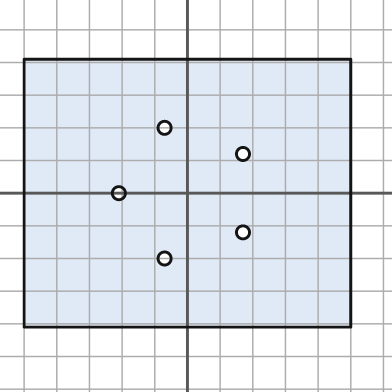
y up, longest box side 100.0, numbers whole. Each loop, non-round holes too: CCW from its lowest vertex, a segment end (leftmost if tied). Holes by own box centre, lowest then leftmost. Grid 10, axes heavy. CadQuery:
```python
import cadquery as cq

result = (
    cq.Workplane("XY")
    .moveTo(-50.0, -41.0)
    .lineTo(50.0, -41.0)
    .lineTo(50.0, 41.0)
    .lineTo(-50.0, 41.0)
    .close()
    .moveTo(-7.0, -20.0)
    .circle(2.0)
    .moveTo(17.0, -12.0)
    .circle(2.0)
    .moveTo(-21.0, 0.0)
    .circle(2.0)
    .moveTo(17.0, 12.0)
    .circle(2.0)
    .moveTo(-7.0, 20.0)
    .circle(2.0)
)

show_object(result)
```